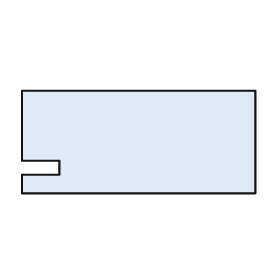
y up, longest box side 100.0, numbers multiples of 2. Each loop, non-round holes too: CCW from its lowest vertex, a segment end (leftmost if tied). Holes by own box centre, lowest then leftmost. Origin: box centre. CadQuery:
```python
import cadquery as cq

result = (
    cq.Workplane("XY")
    .moveTo(-50.0, -22.0)
    .lineTo(50.0, -22.0)
    .lineTo(50.0, 22.0)
    .lineTo(-50.0, 22.0)
    .lineTo(-50.0, -8.0)
    .lineTo(-34.0, -8.0)
    .lineTo(-34.0, -14.0)
    .lineTo(-50.0, -14.0)
    .close()
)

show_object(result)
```